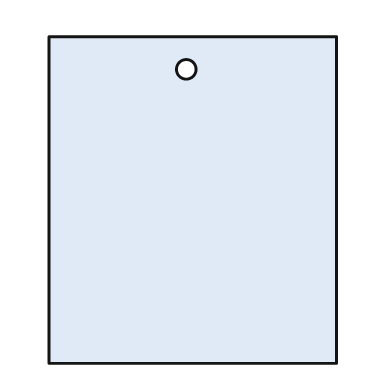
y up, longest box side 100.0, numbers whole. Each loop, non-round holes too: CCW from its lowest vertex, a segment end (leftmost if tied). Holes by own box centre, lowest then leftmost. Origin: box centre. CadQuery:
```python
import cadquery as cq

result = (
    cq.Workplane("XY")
    .moveTo(-44.0, -50.0)
    .lineTo(44.0, -50.0)
    .lineTo(44.0, 50.0)
    .lineTo(-44.0, 50.0)
    .close()
    .moveTo(-2.0, 40.0)
    .circle(3.0)
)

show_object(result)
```